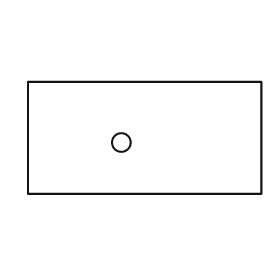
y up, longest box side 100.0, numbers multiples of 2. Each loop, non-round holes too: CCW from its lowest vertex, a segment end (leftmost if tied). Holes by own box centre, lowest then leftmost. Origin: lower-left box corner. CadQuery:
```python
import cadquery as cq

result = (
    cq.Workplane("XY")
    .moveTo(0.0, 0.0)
    .lineTo(100.0, 0.0)
    .lineTo(100.0, 48.0)
    .lineTo(0.0, 48.0)
    .close()
    .moveTo(40.0, 22.0)
    .circle(4.0)
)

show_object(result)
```